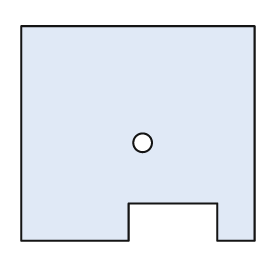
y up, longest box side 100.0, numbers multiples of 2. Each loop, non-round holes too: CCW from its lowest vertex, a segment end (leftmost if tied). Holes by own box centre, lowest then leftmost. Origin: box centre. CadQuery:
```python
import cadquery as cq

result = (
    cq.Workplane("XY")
    .moveTo(-50.0, -46.0)
    .lineTo(-4.0, -46.0)
    .lineTo(-4.0, -30.0)
    .lineTo(34.0, -30.0)
    .lineTo(34.0, -46.0)
    .lineTo(50.0, -46.0)
    .lineTo(50.0, 46.0)
    .lineTo(-50.0, 46.0)
    .close()
    .moveTo(2.0, -4.0)
    .circle(4.0)
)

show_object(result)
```